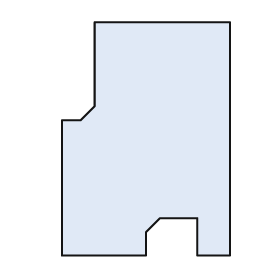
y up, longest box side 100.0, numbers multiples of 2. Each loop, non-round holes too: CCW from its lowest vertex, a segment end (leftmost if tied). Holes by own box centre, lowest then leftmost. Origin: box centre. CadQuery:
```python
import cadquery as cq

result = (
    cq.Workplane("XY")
    .moveTo(-36.0, -50.0)
    .lineTo(0.0, -50.0)
    .lineTo(0.0, -40.0)
    .lineTo(6.0, -34.0)
    .lineTo(22.0, -34.0)
    .lineTo(22.0, -50.0)
    .lineTo(36.0, -50.0)
    .lineTo(36.0, 50.0)
    .lineTo(-22.0, 50.0)
    .lineTo(-22.0, 14.0)
    .lineTo(-28.0, 8.0)
    .lineTo(-36.0, 8.0)
    .close()
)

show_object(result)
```